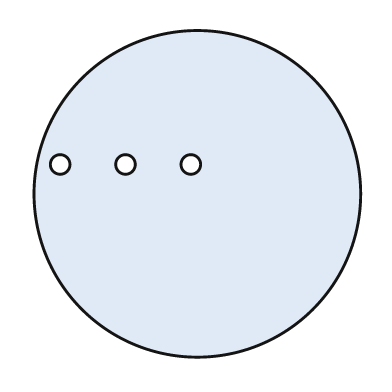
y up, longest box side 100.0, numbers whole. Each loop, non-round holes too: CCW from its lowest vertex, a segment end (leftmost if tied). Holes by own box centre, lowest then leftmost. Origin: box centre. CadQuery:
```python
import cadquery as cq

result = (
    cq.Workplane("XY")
    .moveTo(0.0, 0.0)
    .circle(50.0)
    .moveTo(-42.0, 9.0)
    .circle(3.0)
    .moveTo(-22.0, 9.0)
    .circle(3.0)
    .moveTo(-2.0, 9.0)
    .circle(3.0)
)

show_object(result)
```